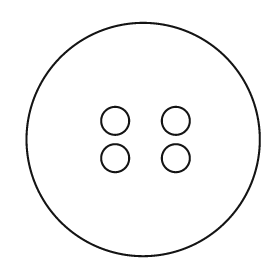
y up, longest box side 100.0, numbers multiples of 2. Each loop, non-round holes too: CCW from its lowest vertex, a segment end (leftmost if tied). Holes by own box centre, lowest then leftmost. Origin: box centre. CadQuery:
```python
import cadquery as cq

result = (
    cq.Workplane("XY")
    .moveTo(0.0, 0.0)
    .circle(50.0)
    .moveTo(-12.0, -8.0)
    .circle(6.0)
    .moveTo(14.0, -8.0)
    .circle(6.0)
    .moveTo(-12.0, 8.0)
    .circle(6.0)
    .moveTo(14.0, 8.0)
    .circle(6.0)
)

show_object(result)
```